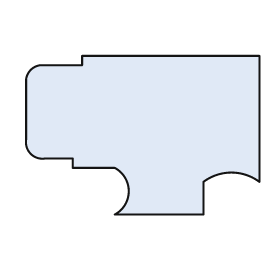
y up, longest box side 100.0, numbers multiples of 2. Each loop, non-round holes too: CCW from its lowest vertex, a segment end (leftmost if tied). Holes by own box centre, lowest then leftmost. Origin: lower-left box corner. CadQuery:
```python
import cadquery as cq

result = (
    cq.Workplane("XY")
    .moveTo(38.0, 0.0)
    .lineTo(76.0, 0.0)
    .lineTo(76.0, 14.0)
    .threePointArc((88.0, 18.0), (100.0, 14.0))
    .lineTo(100.0, 68.0)
    .lineTo(24.0, 68.0)
    .lineTo(24.0, 64.0)
    .lineTo(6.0, 64.0)
    .threePointArc((2.0, 62.0), (0.0, 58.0))
    .lineTo(0.0, 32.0)
    .threePointArc((2.0, 26.0), (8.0, 24.0))
    .lineTo(20.0, 24.0)
    .lineTo(20.0, 20.0)
    .lineTo(38.0, 20.0)
    .threePointArc((44.0, 10.0), (38.0, 0.0))
    .close()
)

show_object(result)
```